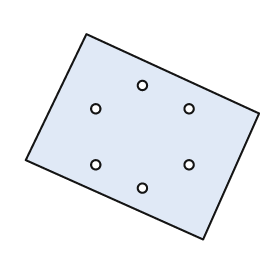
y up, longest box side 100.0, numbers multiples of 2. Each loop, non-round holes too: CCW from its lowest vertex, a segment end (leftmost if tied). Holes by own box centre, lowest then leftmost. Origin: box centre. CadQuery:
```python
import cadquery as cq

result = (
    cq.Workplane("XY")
    .moveTo(26.0, -44.0)
    .lineTo(50.0, 10.0)
    .lineTo(-24.0, 44.0)
    .lineTo(-50.0, -10.0)
    .close()
    .moveTo(0.0, -22.0)
    .circle(2.0)
    .moveTo(-20.0, -12.0)
    .circle(2.0)
    .moveTo(20.0, -12.0)
    .circle(2.0)
    .moveTo(-20.0, 12.0)
    .circle(2.0)
    .moveTo(20.0, 12.0)
    .circle(2.0)
    .moveTo(0.0, 22.0)
    .circle(2.0)
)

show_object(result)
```